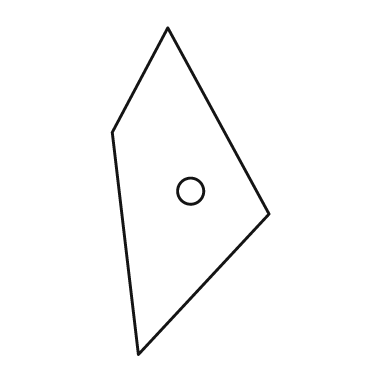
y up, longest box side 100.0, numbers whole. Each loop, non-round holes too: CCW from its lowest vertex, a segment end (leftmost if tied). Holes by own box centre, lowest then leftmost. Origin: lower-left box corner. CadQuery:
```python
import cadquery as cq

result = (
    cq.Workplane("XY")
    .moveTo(8.0, 0.0)
    .lineTo(48.0, 43.0)
    .lineTo(17.0, 100.0)
    .lineTo(0.0, 68.0)
    .close()
    .moveTo(24.0, 50.0)
    .circle(4.0)
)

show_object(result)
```